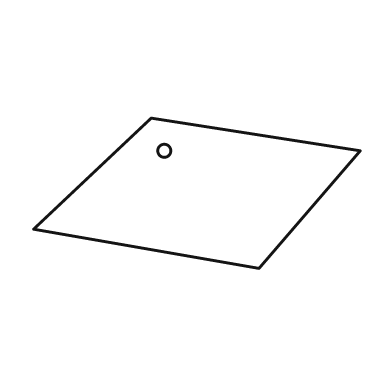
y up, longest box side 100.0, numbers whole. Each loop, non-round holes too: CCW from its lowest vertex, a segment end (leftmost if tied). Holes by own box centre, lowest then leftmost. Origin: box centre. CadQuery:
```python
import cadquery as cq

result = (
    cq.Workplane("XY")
    .moveTo(19.0, -23.0)
    .lineTo(50.0, 13.0)
    .lineTo(-14.0, 23.0)
    .lineTo(-50.0, -11.0)
    .close()
    .moveTo(-10.0, 13.0)
    .circle(2.0)
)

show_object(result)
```